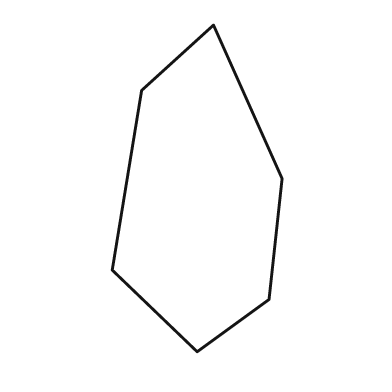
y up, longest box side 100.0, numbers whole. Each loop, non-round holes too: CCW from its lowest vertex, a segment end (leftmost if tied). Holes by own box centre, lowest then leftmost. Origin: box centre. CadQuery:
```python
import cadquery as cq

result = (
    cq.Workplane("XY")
    .moveTo(0.0, -50.0)
    .lineTo(22.0, -34.0)
    .lineTo(26.0, 3.0)
    .lineTo(5.0, 50.0)
    .lineTo(-17.0, 30.0)
    .lineTo(-26.0, -25.0)
    .close()
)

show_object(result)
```